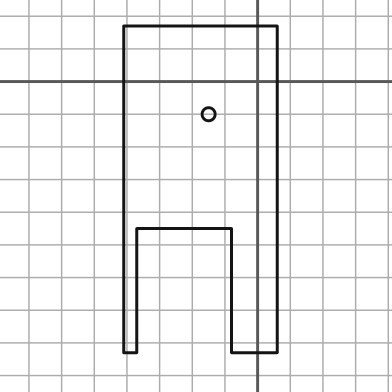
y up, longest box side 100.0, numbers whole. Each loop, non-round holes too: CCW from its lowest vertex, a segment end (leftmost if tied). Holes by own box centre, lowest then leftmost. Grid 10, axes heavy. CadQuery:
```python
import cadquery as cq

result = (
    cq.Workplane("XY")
    .moveTo(-41.0, -83.0)
    .lineTo(-37.0, -83.0)
    .lineTo(-37.0, -45.0)
    .lineTo(-8.0, -45.0)
    .lineTo(-8.0, -83.0)
    .lineTo(6.0, -83.0)
    .lineTo(6.0, 17.0)
    .lineTo(-41.0, 17.0)
    .close()
    .moveTo(-15.0, -10.0)
    .circle(2.0)
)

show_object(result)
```